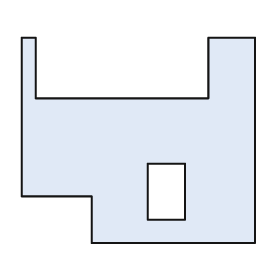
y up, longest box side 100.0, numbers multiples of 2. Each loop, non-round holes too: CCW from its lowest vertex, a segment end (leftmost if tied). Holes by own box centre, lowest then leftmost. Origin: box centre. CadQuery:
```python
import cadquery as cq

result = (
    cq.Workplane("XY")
    .moveTo(-20.0, -44.0)
    .lineTo(50.0, -44.0)
    .lineTo(50.0, 44.0)
    .lineTo(30.0, 44.0)
    .lineTo(30.0, 18.0)
    .lineTo(-44.0, 18.0)
    .lineTo(-44.0, 44.0)
    .lineTo(-50.0, 44.0)
    .lineTo(-50.0, -24.0)
    .lineTo(-20.0, -24.0)
    .close()
    .moveTo(4.0, -34.0)
    .lineTo(20.0, -34.0)
    .lineTo(20.0, -10.0)
    .lineTo(4.0, -10.0)
    .close()
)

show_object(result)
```